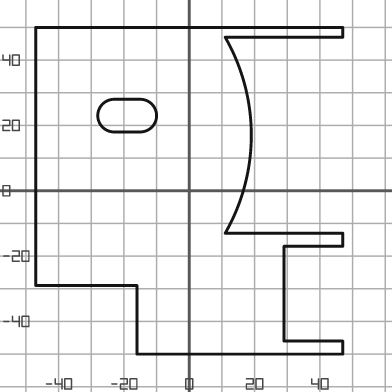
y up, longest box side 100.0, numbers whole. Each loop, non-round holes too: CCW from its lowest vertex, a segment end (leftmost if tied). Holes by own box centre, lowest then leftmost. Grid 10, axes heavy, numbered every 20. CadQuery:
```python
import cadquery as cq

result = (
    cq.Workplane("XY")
    .moveTo(-16.0, -50.0)
    .lineTo(47.0, -50.0)
    .lineTo(47.0, -46.0)
    .lineTo(29.0, -46.0)
    .lineTo(29.0, -17.0)
    .lineTo(47.0, -17.0)
    .lineTo(47.0, -13.0)
    .lineTo(11.0, -13.0)
    .threePointArc((19.0, 17.0), (11.0, 47.0))
    .lineTo(47.0, 47.0)
    .lineTo(47.0, 50.0)
    .lineTo(-47.0, 50.0)
    .lineTo(-47.0, -29.0)
    .lineTo(-16.0, -29.0)
    .close()
    .moveTo(-23.0, 18.0)
    .lineTo(-15.0, 18.0)
    .threePointArc((-10.0, 23.0), (-15.0, 28.0))
    .lineTo(-23.0, 28.0)
    .threePointArc((-28.0, 23.0), (-23.0, 18.0))
    .close()
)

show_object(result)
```